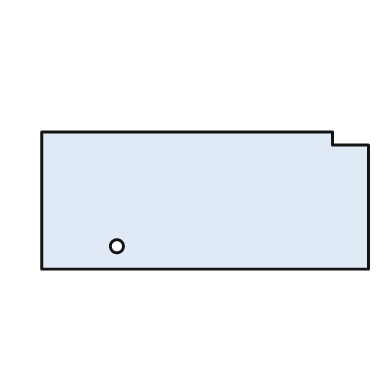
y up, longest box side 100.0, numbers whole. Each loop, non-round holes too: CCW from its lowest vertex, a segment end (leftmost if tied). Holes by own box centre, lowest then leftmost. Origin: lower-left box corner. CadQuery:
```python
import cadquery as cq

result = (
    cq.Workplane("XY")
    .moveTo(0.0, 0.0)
    .lineTo(100.0, 0.0)
    .lineTo(100.0, 38.0)
    .lineTo(89.0, 38.0)
    .lineTo(89.0, 42.0)
    .lineTo(0.0, 42.0)
    .close()
    .moveTo(23.0, 7.0)
    .circle(2.0)
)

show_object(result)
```